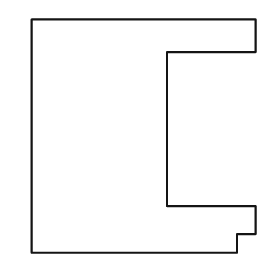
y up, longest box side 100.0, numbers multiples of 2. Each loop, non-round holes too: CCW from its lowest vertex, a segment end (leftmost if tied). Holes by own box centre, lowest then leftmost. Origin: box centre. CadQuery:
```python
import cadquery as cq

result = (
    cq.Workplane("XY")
    .moveTo(-48.0, -50.0)
    .lineTo(40.0, -50.0)
    .lineTo(40.0, -42.0)
    .lineTo(48.0, -42.0)
    .lineTo(48.0, -30.0)
    .lineTo(10.0, -30.0)
    .lineTo(10.0, 36.0)
    .lineTo(48.0, 36.0)
    .lineTo(48.0, 50.0)
    .lineTo(-48.0, 50.0)
    .close()
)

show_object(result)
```